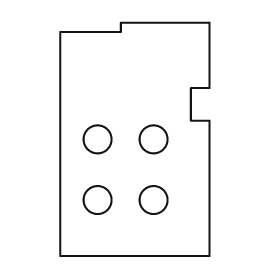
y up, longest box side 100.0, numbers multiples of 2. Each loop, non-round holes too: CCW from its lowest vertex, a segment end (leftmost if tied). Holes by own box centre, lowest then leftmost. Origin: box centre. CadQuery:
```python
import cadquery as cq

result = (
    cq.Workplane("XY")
    .moveTo(-32.0, -50.0)
    .lineTo(32.0, -50.0)
    .lineTo(32.0, 8.0)
    .lineTo(24.0, 8.0)
    .lineTo(24.0, 22.0)
    .lineTo(32.0, 22.0)
    .lineTo(32.0, 50.0)
    .lineTo(-6.0, 50.0)
    .lineTo(-6.0, 46.0)
    .lineTo(-32.0, 46.0)
    .close()
    .moveTo(-16.0, -26.0)
    .circle(6.0)
    .moveTo(8.0, -26.0)
    .circle(6.0)
    .moveTo(-16.0, 0.0)
    .circle(6.0)
    .moveTo(8.0, 0.0)
    .circle(6.0)
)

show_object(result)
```